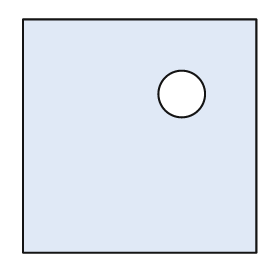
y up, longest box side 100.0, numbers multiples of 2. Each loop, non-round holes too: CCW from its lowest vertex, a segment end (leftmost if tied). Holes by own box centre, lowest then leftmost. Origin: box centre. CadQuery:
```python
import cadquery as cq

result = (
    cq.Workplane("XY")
    .moveTo(-50.0, -50.0)
    .lineTo(50.0, -50.0)
    .lineTo(50.0, 50.0)
    .lineTo(-50.0, 50.0)
    .close()
    .moveTo(18.0, 18.0)
    .circle(10.0)
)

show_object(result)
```